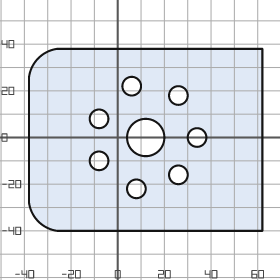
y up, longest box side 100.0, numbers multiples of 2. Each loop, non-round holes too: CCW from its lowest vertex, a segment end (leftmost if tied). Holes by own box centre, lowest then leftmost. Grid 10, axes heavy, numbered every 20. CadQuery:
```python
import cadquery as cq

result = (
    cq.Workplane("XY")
    .moveTo(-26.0, -40.0)
    .lineTo(62.0, -40.0)
    .lineTo(62.0, 38.0)
    .lineTo(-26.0, 38.0)
    .threePointArc((-34.0, 34.0), (-38.0, 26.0))
    .lineTo(-38.0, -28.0)
    .threePointArc((-34.0, -36.0), (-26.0, -40.0))
    .close()
    .moveTo(8.0, -22.0)
    .circle(4.0)
    .moveTo(26.0, -16.0)
    .circle(4.0)
    .moveTo(-8.0, -10.0)
    .circle(4.0)
    .moveTo(12.0, 0.0)
    .circle(8.0)
    .moveTo(34.0, 0.0)
    .circle(4.0)
    .moveTo(-8.0, 8.0)
    .circle(4.0)
    .moveTo(26.0, 18.0)
    .circle(4.0)
    .moveTo(6.0, 22.0)
    .circle(4.0)
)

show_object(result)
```